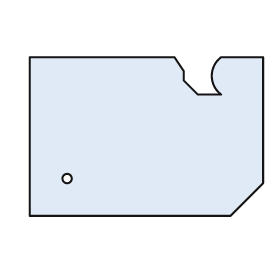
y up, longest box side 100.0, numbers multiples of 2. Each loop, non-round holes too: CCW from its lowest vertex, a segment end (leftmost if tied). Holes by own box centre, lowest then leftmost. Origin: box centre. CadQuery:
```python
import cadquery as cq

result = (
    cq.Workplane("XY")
    .moveTo(-50.0, -34.0)
    .lineTo(36.0, -34.0)
    .lineTo(50.0, -20.0)
    .lineTo(50.0, 34.0)
    .lineTo(32.0, 34.0)
    .threePointArc((28.0, 26.0), (32.0, 18.0))
    .lineTo(22.0, 18.0)
    .lineTo(16.0, 24.0)
    .lineTo(16.0, 28.0)
    .lineTo(12.0, 34.0)
    .lineTo(-50.0, 34.0)
    .close()
    .moveTo(-34.0, -18.0)
    .circle(2.0)
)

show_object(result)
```